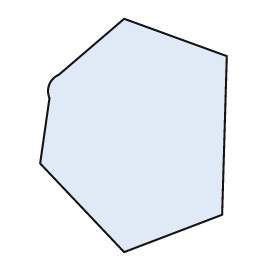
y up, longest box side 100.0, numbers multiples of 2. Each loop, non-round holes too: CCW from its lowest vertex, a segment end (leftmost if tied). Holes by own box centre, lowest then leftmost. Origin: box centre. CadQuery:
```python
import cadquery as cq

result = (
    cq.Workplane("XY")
    .moveTo(-4.0, -50.0)
    .lineTo(38.0, -34.0)
    .lineTo(40.0, 34.0)
    .lineTo(-4.0, 50.0)
    .lineTo(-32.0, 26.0)
    .threePointArc((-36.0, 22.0), (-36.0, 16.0))
    .lineTo(-40.0, -12.0)
    .close()
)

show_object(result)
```